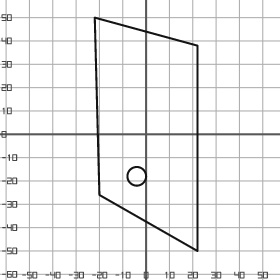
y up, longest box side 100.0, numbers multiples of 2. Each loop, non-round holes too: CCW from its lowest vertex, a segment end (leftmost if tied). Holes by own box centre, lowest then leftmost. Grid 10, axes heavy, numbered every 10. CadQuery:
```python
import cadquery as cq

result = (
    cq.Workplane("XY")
    .moveTo(22.0, -50.0)
    .lineTo(22.0, 38.0)
    .lineTo(-22.0, 50.0)
    .lineTo(-20.0, -26.0)
    .close()
    .moveTo(-4.0, -18.0)
    .circle(4.0)
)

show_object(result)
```